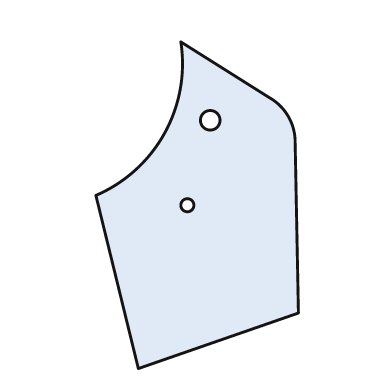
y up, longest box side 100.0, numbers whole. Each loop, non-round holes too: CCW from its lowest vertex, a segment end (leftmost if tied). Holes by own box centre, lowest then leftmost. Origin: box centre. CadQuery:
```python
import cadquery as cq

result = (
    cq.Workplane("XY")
    .moveTo(-18.0, -50.0)
    .lineTo(31.0, -33.0)
    .lineTo(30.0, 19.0)
    .threePointArc((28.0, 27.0), (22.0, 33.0))
    .lineTo(-5.0, 50.0)
    .threePointArc((-10.0, 22.0), (-31.0, 3.0))
    .close()
    .moveTo(-3.0, 0.0)
    .circle(2.0)
    .moveTo(4.0, 26.0)
    .circle(3.0)
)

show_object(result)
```